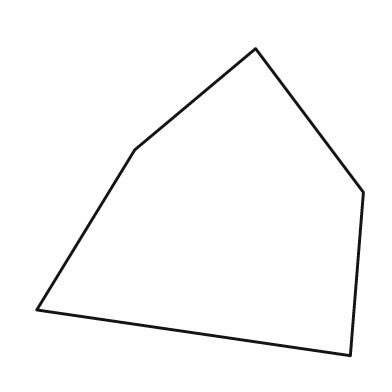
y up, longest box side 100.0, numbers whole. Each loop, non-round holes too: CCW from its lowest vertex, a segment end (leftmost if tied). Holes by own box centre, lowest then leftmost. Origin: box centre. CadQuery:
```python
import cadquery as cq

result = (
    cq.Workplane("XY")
    .moveTo(46.0, -47.0)
    .lineTo(50.0, 3.0)
    .lineTo(17.0, 47.0)
    .lineTo(-20.0, 16.0)
    .lineTo(-50.0, -33.0)
    .close()
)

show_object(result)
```